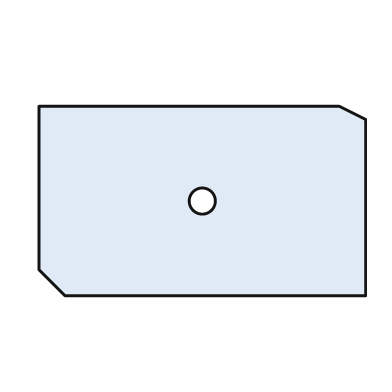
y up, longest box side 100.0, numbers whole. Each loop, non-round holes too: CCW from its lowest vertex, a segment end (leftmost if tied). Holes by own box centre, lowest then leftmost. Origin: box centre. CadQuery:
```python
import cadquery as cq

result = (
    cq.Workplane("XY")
    .moveTo(-42.0, -29.0)
    .lineTo(50.0, -29.0)
    .lineTo(50.0, 25.0)
    .lineTo(42.0, 29.0)
    .lineTo(-50.0, 29.0)
    .lineTo(-50.0, -21.0)
    .close()
    .moveTo(0.0, 0.0)
    .circle(4.0)
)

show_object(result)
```